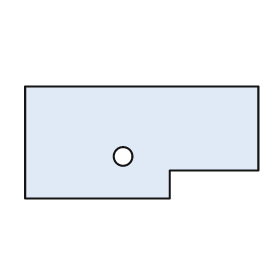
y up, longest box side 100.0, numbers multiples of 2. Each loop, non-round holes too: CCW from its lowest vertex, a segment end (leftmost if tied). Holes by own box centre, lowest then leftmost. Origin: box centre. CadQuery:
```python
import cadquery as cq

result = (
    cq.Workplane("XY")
    .moveTo(-50.0, -24.0)
    .lineTo(12.0, -24.0)
    .lineTo(12.0, -12.0)
    .lineTo(50.0, -12.0)
    .lineTo(50.0, 24.0)
    .lineTo(-50.0, 24.0)
    .close()
    .moveTo(-8.0, -6.0)
    .circle(4.0)
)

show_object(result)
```